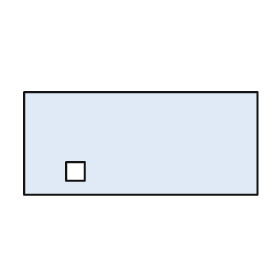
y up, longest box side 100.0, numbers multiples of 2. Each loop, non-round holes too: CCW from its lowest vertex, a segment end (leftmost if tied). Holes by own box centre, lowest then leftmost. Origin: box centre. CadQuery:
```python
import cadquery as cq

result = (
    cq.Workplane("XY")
    .moveTo(-50.0, -22.0)
    .lineTo(50.0, -22.0)
    .lineTo(50.0, 22.0)
    .lineTo(-50.0, 22.0)
    .close()
    .moveTo(-32.0, -16.0)
    .lineTo(-24.0, -16.0)
    .lineTo(-24.0, -8.0)
    .lineTo(-32.0, -8.0)
    .close()
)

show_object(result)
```